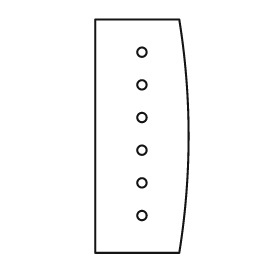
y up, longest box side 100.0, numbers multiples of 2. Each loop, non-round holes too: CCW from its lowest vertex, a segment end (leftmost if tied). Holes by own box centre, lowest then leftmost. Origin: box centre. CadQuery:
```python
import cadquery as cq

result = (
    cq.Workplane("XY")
    .moveTo(-20.0, -50.0)
    .lineTo(16.0, -50.0)
    .threePointArc((20.0, 0.0), (16.0, 50.0))
    .lineTo(-20.0, 50.0)
    .close()
    .moveTo(0.0, -34.0)
    .circle(2.0)
    .moveTo(0.0, -20.0)
    .circle(2.0)
    .moveTo(0.0, -6.0)
    .circle(2.0)
    .moveTo(0.0, 8.0)
    .circle(2.0)
    .moveTo(0.0, 22.0)
    .circle(2.0)
    .moveTo(0.0, 36.0)
    .circle(2.0)
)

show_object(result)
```